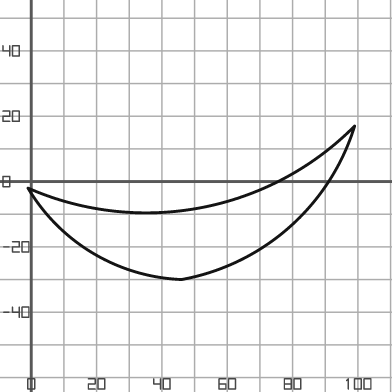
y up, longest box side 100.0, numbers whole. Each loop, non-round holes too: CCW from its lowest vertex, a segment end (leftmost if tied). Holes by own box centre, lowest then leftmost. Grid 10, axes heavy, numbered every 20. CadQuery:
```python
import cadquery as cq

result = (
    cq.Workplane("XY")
    .moveTo(46.0, -30.0)
    .threePointArc((79.0, -14.0), (99.0, 17.0))
    .threePointArc((52.0, -8.0), (-1.0, -2.0))
    .threePointArc((19.0, -22.0), (46.0, -30.0))
    .close()
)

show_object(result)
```